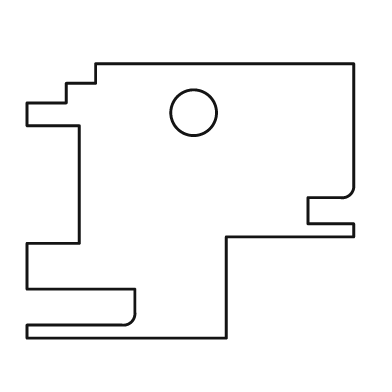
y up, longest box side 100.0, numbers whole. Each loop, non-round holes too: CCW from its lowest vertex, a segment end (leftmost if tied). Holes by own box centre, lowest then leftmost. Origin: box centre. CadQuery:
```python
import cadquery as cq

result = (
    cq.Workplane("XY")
    .moveTo(-50.0, -42.0)
    .lineTo(11.0, -42.0)
    .lineTo(11.0, -11.0)
    .lineTo(50.0, -11.0)
    .lineTo(50.0, -7.0)
    .lineTo(36.0, -7.0)
    .lineTo(36.0, 1.0)
    .lineTo(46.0, 1.0)
    .threePointArc((49.0, 2.0), (50.0, 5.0))
    .lineTo(50.0, 42.0)
    .lineTo(-29.0, 42.0)
    .lineTo(-29.0, 36.0)
    .lineTo(-38.0, 36.0)
    .lineTo(-38.0, 30.0)
    .lineTo(-50.0, 30.0)
    .lineTo(-50.0, 23.0)
    .lineTo(-34.0, 23.0)
    .lineTo(-34.0, -13.0)
    .lineTo(-50.0, -13.0)
    .lineTo(-50.0, -27.0)
    .lineTo(-17.0, -27.0)
    .lineTo(-17.0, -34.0)
    .threePointArc((-18.0, -37.0), (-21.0, -38.0))
    .lineTo(-50.0, -38.0)
    .close()
    .moveTo(1.0, 27.0)
    .circle(7.0)
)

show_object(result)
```